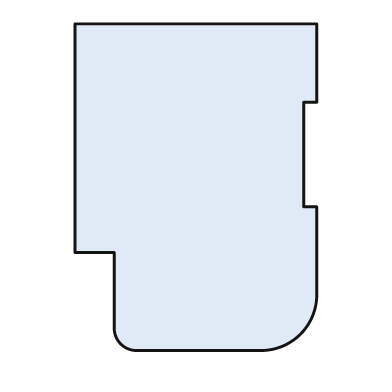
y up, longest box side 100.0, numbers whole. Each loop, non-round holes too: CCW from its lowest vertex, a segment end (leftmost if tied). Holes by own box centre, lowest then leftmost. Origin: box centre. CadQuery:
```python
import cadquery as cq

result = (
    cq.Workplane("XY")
    .moveTo(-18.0, -50.0)
    .lineTo(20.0, -50.0)
    .threePointArc((32.0, -45.0), (37.0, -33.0))
    .lineTo(37.0, -6.0)
    .lineTo(33.0, -6.0)
    .lineTo(33.0, 26.0)
    .lineTo(37.0, 26.0)
    .lineTo(37.0, 50.0)
    .lineTo(-37.0, 50.0)
    .lineTo(-37.0, -20.0)
    .lineTo(-25.0, -20.0)
    .lineTo(-25.0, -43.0)
    .threePointArc((-23.0, -48.0), (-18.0, -50.0))
    .close()
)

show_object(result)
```